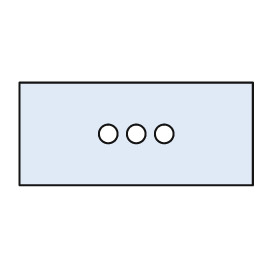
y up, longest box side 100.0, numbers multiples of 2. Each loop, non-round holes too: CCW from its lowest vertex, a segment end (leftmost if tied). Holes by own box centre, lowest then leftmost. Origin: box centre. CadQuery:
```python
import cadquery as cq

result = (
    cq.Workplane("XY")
    .moveTo(-50.0, -22.0)
    .lineTo(50.0, -22.0)
    .lineTo(50.0, 22.0)
    .lineTo(-50.0, 22.0)
    .close()
    .moveTo(-12.0, 0.0)
    .circle(4.0)
    .moveTo(0.0, 0.0)
    .circle(4.0)
    .moveTo(12.0, 0.0)
    .circle(4.0)
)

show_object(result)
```